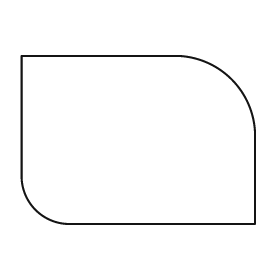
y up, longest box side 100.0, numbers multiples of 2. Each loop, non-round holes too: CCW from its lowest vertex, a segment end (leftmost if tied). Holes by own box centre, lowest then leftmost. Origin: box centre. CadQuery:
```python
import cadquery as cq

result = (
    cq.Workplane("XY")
    .moveTo(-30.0, -36.0)
    .lineTo(50.0, -36.0)
    .lineTo(50.0, 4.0)
    .threePointArc((40.0, 26.0), (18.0, 36.0))
    .lineTo(-50.0, 36.0)
    .lineTo(-50.0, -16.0)
    .threePointArc((-44.0, -30.0), (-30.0, -36.0))
    .close()
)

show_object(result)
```